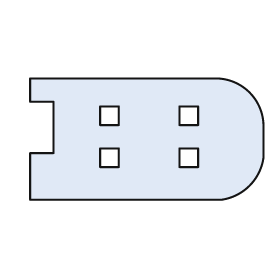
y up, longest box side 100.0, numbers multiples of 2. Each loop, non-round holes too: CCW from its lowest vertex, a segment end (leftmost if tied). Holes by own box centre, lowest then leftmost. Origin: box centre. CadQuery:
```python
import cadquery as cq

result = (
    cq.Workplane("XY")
    .moveTo(-50.0, -26.0)
    .lineTo(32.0, -26.0)
    .threePointArc((44.0, -20.0), (50.0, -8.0))
    .lineTo(50.0, 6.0)
    .threePointArc((44.0, 20.0), (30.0, 26.0))
    .lineTo(-50.0, 26.0)
    .lineTo(-50.0, 16.0)
    .lineTo(-40.0, 16.0)
    .lineTo(-40.0, -6.0)
    .lineTo(-50.0, -6.0)
    .close()
    .moveTo(-20.0, -12.0)
    .lineTo(-12.0, -12.0)
    .lineTo(-12.0, -4.0)
    .lineTo(-20.0, -4.0)
    .close()
    .moveTo(14.0, -12.0)
    .lineTo(22.0, -12.0)
    .lineTo(22.0, -4.0)
    .lineTo(14.0, -4.0)
    .close()
    .moveTo(-20.0, 6.0)
    .lineTo(-12.0, 6.0)
    .lineTo(-12.0, 14.0)
    .lineTo(-20.0, 14.0)
    .close()
    .moveTo(14.0, 6.0)
    .lineTo(22.0, 6.0)
    .lineTo(22.0, 14.0)
    .lineTo(14.0, 14.0)
    .close()
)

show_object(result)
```